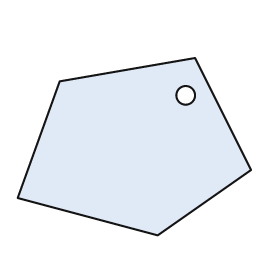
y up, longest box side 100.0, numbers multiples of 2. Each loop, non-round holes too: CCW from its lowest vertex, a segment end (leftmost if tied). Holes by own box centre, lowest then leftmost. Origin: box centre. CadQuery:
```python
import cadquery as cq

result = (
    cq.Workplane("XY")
    .moveTo(10.0, -38.0)
    .lineTo(50.0, -10.0)
    .lineTo(26.0, 38.0)
    .lineTo(-32.0, 28.0)
    .lineTo(-50.0, -22.0)
    .close()
    .moveTo(22.0, 22.0)
    .circle(4.0)
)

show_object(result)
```